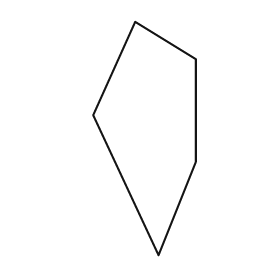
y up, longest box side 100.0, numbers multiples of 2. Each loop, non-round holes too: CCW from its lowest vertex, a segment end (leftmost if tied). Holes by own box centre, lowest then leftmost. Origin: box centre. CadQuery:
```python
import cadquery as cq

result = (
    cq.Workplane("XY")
    .moveTo(6.0, -50.0)
    .lineTo(22.0, -10.0)
    .lineTo(22.0, 34.0)
    .lineTo(-4.0, 50.0)
    .lineTo(-22.0, 10.0)
    .close()
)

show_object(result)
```